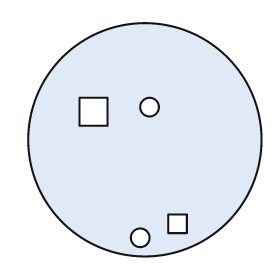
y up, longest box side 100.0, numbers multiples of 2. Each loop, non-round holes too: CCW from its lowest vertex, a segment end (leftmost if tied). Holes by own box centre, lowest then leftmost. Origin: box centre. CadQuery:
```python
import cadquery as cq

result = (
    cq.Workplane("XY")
    .moveTo(0.0, 0.0)
    .circle(50.0)
    .moveTo(-2.0, -42.0)
    .circle(4.0)
    .moveTo(10.0, -40.0)
    .lineTo(18.0, -40.0)
    .lineTo(18.0, -32.0)
    .lineTo(10.0, -32.0)
    .close()
    .moveTo(-28.0, 6.0)
    .lineTo(-16.0, 6.0)
    .lineTo(-16.0, 18.0)
    .lineTo(-28.0, 18.0)
    .close()
    .moveTo(2.0, 14.0)
    .circle(4.0)
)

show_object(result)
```